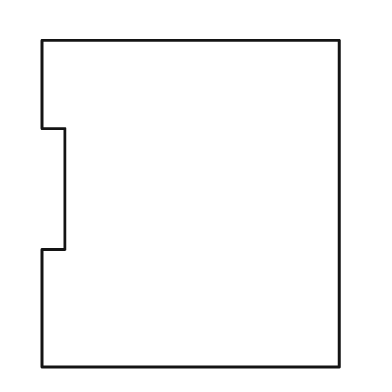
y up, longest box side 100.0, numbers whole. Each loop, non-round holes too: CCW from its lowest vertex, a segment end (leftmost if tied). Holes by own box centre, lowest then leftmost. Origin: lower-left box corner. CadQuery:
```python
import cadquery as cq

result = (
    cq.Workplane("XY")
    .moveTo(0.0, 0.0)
    .lineTo(91.0, 0.0)
    .lineTo(91.0, 100.0)
    .lineTo(0.0, 100.0)
    .lineTo(0.0, 73.0)
    .lineTo(7.0, 73.0)
    .lineTo(7.0, 36.0)
    .lineTo(0.0, 36.0)
    .close()
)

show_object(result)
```